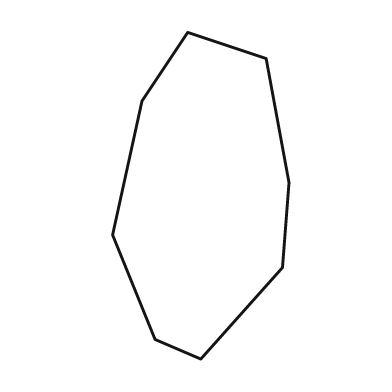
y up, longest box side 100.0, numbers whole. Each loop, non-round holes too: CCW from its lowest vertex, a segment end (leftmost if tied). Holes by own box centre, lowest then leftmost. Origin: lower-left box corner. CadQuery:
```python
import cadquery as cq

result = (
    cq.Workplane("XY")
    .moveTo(27.0, 0.0)
    .lineTo(52.0, 28.0)
    .lineTo(54.0, 54.0)
    .lineTo(47.0, 92.0)
    .lineTo(23.0, 100.0)
    .lineTo(9.0, 79.0)
    .lineTo(0.0, 38.0)
    .lineTo(13.0, 6.0)
    .close()
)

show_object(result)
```